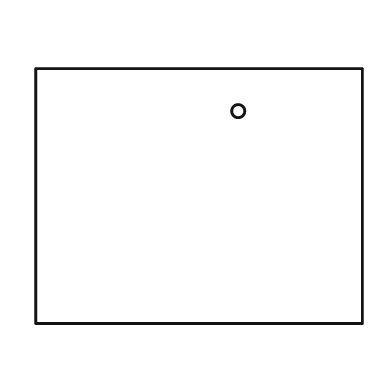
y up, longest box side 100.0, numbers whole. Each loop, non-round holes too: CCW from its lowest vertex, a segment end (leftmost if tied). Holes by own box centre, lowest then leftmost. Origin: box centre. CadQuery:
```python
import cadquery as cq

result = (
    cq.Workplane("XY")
    .moveTo(-50.0, -39.0)
    .lineTo(50.0, -39.0)
    .lineTo(50.0, 39.0)
    .lineTo(-50.0, 39.0)
    .close()
    .moveTo(12.0, 26.0)
    .circle(2.0)
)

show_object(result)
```